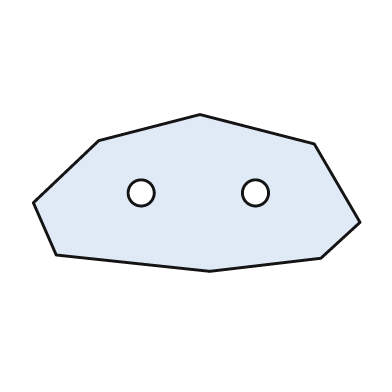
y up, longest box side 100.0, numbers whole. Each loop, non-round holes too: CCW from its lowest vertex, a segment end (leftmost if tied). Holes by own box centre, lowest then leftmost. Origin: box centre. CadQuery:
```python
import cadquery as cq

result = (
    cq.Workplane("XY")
    .moveTo(4.0, -24.0)
    .lineTo(38.0, -20.0)
    .lineTo(50.0, -9.0)
    .lineTo(36.0, 15.0)
    .lineTo(1.0, 24.0)
    .lineTo(-30.0, 16.0)
    .lineTo(-50.0, -3.0)
    .lineTo(-43.0, -19.0)
    .close()
    .moveTo(-17.0, 0.0)
    .circle(4.0)
    .moveTo(18.0, 0.0)
    .circle(4.0)
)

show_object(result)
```